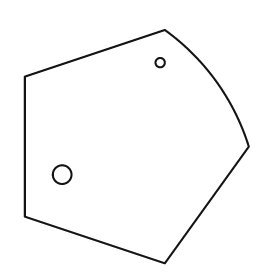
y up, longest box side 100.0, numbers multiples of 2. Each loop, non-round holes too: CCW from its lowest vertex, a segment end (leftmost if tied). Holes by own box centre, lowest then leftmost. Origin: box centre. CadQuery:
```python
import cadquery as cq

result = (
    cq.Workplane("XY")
    .moveTo(12.0, -50.0)
    .lineTo(48.0, 0.0)
    .threePointArc((34.0, 28.0), (12.0, 50.0))
    .lineTo(-48.0, 30.0)
    .lineTo(-48.0, -30.0)
    .close()
    .moveTo(-32.0, -12.0)
    .circle(4.0)
    .moveTo(10.0, 36.0)
    .circle(2.0)
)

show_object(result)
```